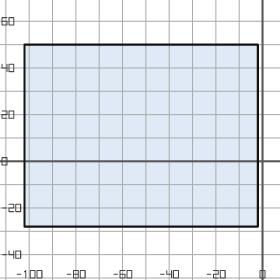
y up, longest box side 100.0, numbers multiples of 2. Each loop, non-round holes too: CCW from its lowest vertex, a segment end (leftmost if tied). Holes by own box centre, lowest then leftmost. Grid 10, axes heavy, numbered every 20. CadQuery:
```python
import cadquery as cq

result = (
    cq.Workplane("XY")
    .moveTo(-102.0, -28.0)
    .lineTo(-2.0, -28.0)
    .lineTo(-2.0, 50.0)
    .lineTo(-102.0, 50.0)
    .close()
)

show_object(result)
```